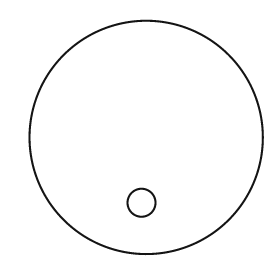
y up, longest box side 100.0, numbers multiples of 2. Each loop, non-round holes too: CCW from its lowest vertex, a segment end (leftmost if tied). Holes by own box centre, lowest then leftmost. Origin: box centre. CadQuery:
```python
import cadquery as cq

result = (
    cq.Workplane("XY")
    .moveTo(0.0, 0.0)
    .circle(50.0)
    .moveTo(-2.0, -28.0)
    .circle(6.0)
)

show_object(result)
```